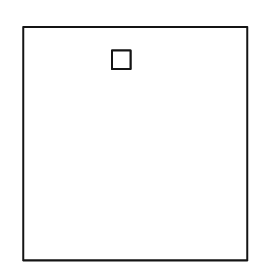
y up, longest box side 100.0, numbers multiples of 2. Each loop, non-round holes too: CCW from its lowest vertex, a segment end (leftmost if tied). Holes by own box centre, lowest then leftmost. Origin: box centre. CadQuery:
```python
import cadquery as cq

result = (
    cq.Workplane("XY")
    .moveTo(-48.0, -50.0)
    .lineTo(48.0, -50.0)
    .lineTo(48.0, 50.0)
    .lineTo(-48.0, 50.0)
    .close()
    .moveTo(-10.0, 32.0)
    .lineTo(-2.0, 32.0)
    .lineTo(-2.0, 40.0)
    .lineTo(-10.0, 40.0)
    .close()
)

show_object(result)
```